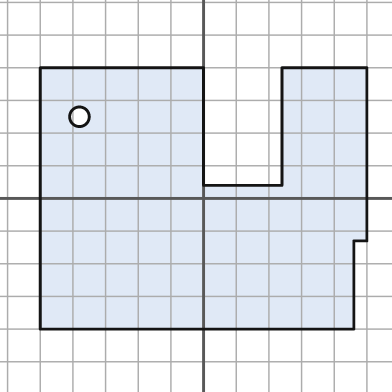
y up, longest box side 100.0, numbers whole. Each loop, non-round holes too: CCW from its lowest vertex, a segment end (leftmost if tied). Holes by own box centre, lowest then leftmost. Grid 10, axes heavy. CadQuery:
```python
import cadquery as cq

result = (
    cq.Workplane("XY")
    .moveTo(-50.0, -40.0)
    .lineTo(46.0, -40.0)
    .lineTo(46.0, -13.0)
    .lineTo(50.0, -13.0)
    .lineTo(50.0, 40.0)
    .lineTo(24.0, 40.0)
    .lineTo(24.0, 4.0)
    .lineTo(0.0, 4.0)
    .lineTo(0.0, 40.0)
    .lineTo(-50.0, 40.0)
    .close()
    .moveTo(-38.0, 25.0)
    .circle(3.0)
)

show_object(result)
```